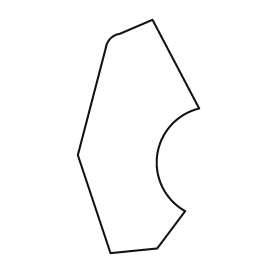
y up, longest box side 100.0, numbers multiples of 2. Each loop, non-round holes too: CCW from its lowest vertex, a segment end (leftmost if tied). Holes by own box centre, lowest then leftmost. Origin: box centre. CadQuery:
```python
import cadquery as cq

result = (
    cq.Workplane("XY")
    .moveTo(-12.0, -50.0)
    .lineTo(8.0, -48.0)
    .lineTo(20.0, -32.0)
    .threePointArc((8.0, -8.0), (26.0, 12.0))
    .lineTo(6.0, 50.0)
    .lineTo(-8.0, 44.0)
    .threePointArc((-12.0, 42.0), (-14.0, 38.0))
    .lineTo(-26.0, -8.0)
    .close()
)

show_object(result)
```